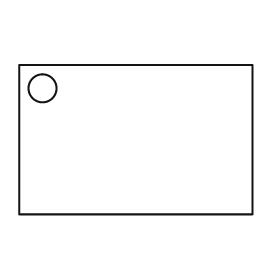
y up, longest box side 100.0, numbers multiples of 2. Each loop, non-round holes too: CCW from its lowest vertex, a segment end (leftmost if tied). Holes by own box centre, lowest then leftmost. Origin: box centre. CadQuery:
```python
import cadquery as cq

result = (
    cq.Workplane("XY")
    .moveTo(-50.0, -32.0)
    .lineTo(50.0, -32.0)
    .lineTo(50.0, 32.0)
    .lineTo(-50.0, 32.0)
    .close()
    .moveTo(-40.0, 22.0)
    .circle(6.0)
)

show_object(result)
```